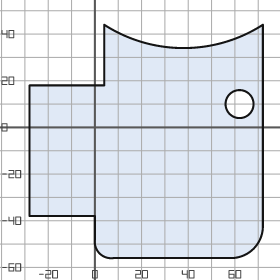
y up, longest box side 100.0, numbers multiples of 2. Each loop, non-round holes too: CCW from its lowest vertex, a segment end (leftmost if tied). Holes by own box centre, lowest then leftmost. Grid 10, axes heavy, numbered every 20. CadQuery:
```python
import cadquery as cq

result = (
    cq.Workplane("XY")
    .moveTo(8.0, -56.0)
    .lineTo(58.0, -56.0)
    .threePointArc((68.0, -52.0), (72.0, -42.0))
    .lineTo(72.0, 44.0)
    .threePointArc((38.0, 34.0), (4.0, 44.0))
    .lineTo(4.0, 18.0)
    .lineTo(-28.0, 18.0)
    .lineTo(-28.0, -38.0)
    .lineTo(0.0, -38.0)
    .lineTo(0.0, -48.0)
    .threePointArc((2.0, -54.0), (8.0, -56.0))
    .close()
    .moveTo(62.0, 10.0)
    .circle(6.0)
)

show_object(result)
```